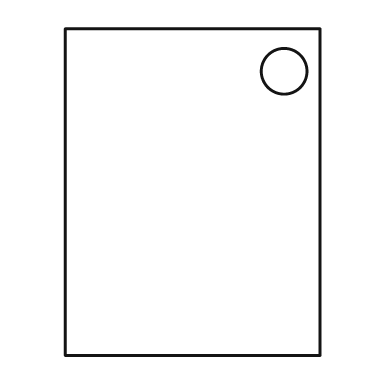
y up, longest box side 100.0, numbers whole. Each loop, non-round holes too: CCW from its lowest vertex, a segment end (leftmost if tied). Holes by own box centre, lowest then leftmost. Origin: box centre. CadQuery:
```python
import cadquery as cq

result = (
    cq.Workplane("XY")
    .moveTo(-39.0, -50.0)
    .lineTo(39.0, -50.0)
    .lineTo(39.0, 50.0)
    .lineTo(-39.0, 50.0)
    .close()
    .moveTo(28.0, 37.0)
    .circle(7.0)
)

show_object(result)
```